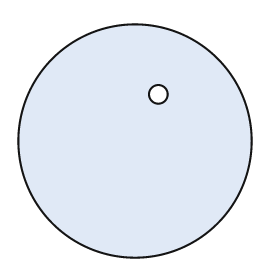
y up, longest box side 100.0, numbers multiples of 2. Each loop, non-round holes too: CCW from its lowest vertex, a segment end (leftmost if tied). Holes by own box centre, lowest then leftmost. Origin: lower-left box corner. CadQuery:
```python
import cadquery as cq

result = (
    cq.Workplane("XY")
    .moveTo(50.0, 50.0)
    .circle(50.0)
    .moveTo(60.0, 70.0)
    .circle(4.0)
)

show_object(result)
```